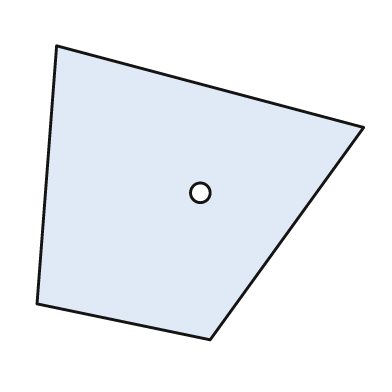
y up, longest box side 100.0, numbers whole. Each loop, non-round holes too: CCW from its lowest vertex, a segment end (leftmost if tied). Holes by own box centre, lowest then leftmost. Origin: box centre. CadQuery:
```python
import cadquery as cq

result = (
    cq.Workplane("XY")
    .moveTo(3.0, -45.0)
    .lineTo(50.0, 20.0)
    .lineTo(-44.0, 45.0)
    .lineTo(-50.0, -34.0)
    .close()
    .moveTo(0.0, 0.0)
    .circle(3.0)
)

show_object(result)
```